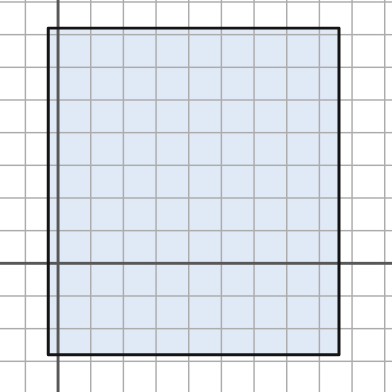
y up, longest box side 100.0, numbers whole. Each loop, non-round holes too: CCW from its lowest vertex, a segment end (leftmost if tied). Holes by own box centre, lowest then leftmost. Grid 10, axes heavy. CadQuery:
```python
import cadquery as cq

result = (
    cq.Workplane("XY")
    .moveTo(-3.0, -28.0)
    .lineTo(86.0, -28.0)
    .lineTo(86.0, 72.0)
    .lineTo(-3.0, 72.0)
    .close()
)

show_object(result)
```